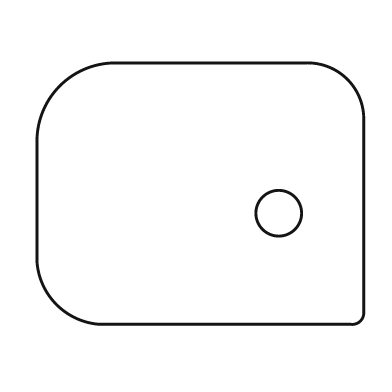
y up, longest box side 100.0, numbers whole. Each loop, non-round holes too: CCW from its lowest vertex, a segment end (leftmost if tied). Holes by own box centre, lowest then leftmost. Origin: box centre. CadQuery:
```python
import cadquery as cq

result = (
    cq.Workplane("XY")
    .moveTo(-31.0, -40.0)
    .lineTo(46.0, -40.0)
    .threePointArc((49.0, -39.0), (50.0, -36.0))
    .lineTo(50.0, 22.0)
    .threePointArc((45.0, 35.0), (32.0, 40.0))
    .lineTo(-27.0, 40.0)
    .threePointArc((-43.0, 33.0), (-50.0, 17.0))
    .lineTo(-50.0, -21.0)
    .threePointArc((-44.0, -34.0), (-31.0, -40.0))
    .close()
    .moveTo(24.0, -6.0)
    .circle(7.0)
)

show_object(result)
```